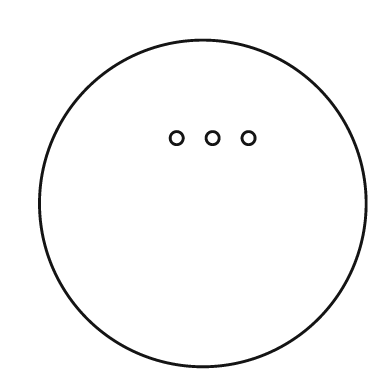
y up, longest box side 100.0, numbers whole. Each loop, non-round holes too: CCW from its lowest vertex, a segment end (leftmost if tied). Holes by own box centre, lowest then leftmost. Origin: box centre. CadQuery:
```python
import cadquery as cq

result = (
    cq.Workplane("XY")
    .moveTo(0.0, 0.0)
    .circle(50.0)
    .moveTo(-8.0, 20.0)
    .circle(2.0)
    .moveTo(3.0, 20.0)
    .circle(2.0)
    .moveTo(14.0, 20.0)
    .circle(2.0)
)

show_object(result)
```